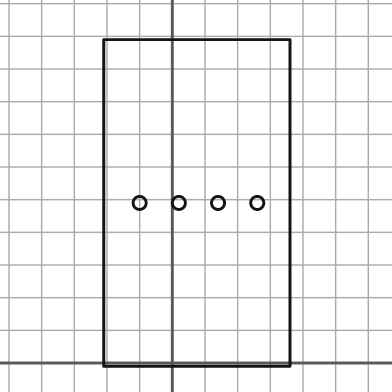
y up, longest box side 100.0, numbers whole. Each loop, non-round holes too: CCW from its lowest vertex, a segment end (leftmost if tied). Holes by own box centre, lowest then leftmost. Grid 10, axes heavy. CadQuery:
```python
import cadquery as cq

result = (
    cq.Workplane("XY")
    .moveTo(-21.0, -1.0)
    .lineTo(36.0, -1.0)
    .lineTo(36.0, 99.0)
    .lineTo(-21.0, 99.0)
    .close()
    .moveTo(-10.0, 49.0)
    .circle(2.0)
    .moveTo(2.0, 49.0)
    .circle(2.0)
    .moveTo(14.0, 49.0)
    .circle(2.0)
    .moveTo(26.0, 49.0)
    .circle(2.0)
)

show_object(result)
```